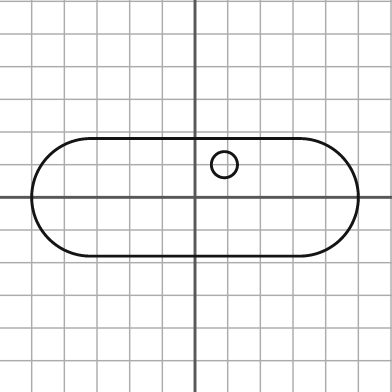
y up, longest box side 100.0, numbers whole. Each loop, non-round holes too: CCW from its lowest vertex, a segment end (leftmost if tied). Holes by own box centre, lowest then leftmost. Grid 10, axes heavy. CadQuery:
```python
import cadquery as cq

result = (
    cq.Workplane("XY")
    .moveTo(-32.0, -18.0)
    .lineTo(32.0, -18.0)
    .threePointArc((50.0, 0.0), (32.0, 18.0))
    .lineTo(-32.0, 18.0)
    .threePointArc((-50.0, 0.0), (-32.0, -18.0))
    .close()
    .moveTo(9.0, 10.0)
    .circle(4.0)
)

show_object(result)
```